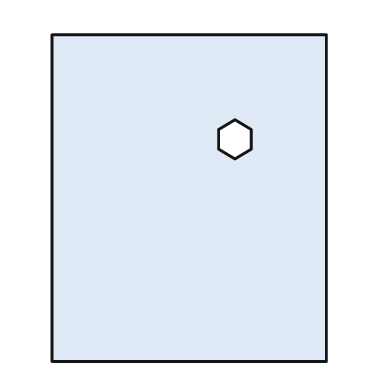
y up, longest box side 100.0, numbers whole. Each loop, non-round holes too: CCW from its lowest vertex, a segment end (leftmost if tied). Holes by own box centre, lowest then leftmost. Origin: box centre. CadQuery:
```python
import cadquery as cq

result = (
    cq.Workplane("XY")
    .moveTo(-42.0, -50.0)
    .lineTo(42.0, -50.0)
    .lineTo(42.0, 50.0)
    .lineTo(-42.0, 50.0)
    .close()
    .moveTo(14.0, 12.0)
    .lineTo(19.0, 15.0)
    .lineTo(19.0, 21.0)
    .lineTo(14.0, 24.0)
    .lineTo(9.0, 21.0)
    .lineTo(9.0, 15.0)
    .close()
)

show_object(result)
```